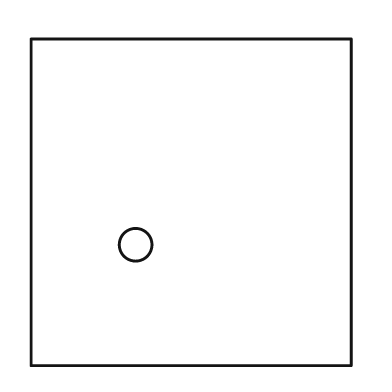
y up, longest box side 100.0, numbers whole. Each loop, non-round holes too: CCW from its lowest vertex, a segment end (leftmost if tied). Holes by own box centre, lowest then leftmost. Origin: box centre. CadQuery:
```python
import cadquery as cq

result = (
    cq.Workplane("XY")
    .moveTo(-49.0, -50.0)
    .lineTo(49.0, -50.0)
    .lineTo(49.0, 50.0)
    .lineTo(-49.0, 50.0)
    .close()
    .moveTo(-17.0, -13.0)
    .circle(5.0)
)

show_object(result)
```